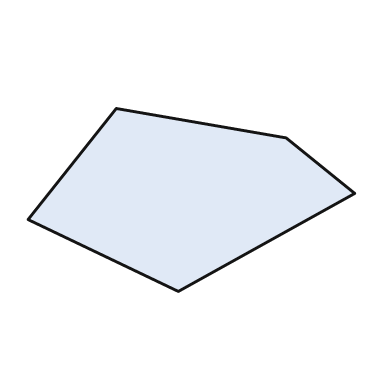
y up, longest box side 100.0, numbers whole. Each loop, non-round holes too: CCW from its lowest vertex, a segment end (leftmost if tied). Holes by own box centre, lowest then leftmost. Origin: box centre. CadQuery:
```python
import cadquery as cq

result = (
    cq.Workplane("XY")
    .moveTo(-4.0, -28.0)
    .lineTo(50.0, 2.0)
    .lineTo(29.0, 19.0)
    .lineTo(-23.0, 28.0)
    .lineTo(-50.0, -6.0)
    .close()
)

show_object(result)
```